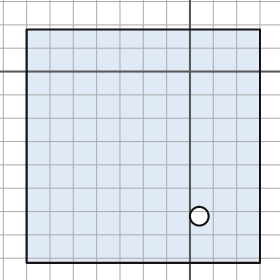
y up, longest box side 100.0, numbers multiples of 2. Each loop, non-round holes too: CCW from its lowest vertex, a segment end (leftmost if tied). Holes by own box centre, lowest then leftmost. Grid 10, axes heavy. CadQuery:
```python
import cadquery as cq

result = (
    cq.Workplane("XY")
    .moveTo(-70.0, -82.0)
    .lineTo(30.0, -82.0)
    .lineTo(30.0, 18.0)
    .lineTo(-70.0, 18.0)
    .close()
    .moveTo(4.0, -62.0)
    .circle(4.0)
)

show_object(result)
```